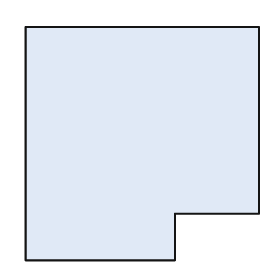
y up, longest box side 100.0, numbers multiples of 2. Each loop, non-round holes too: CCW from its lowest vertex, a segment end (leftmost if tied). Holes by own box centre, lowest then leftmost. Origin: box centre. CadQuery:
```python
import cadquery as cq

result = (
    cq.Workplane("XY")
    .moveTo(-50.0, -50.0)
    .lineTo(14.0, -50.0)
    .lineTo(14.0, -30.0)
    .lineTo(50.0, -30.0)
    .lineTo(50.0, 50.0)
    .lineTo(-50.0, 50.0)
    .close()
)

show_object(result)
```